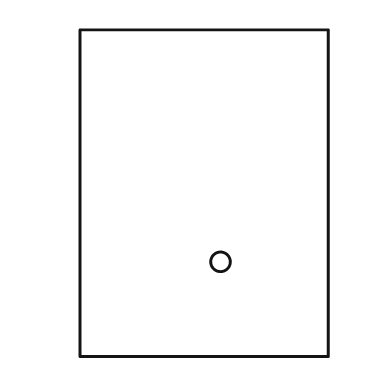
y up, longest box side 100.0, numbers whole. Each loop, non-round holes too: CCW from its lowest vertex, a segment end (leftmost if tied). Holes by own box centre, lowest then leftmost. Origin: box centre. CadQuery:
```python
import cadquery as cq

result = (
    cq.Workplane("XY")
    .moveTo(-38.0, -50.0)
    .lineTo(38.0, -50.0)
    .lineTo(38.0, 50.0)
    .lineTo(-38.0, 50.0)
    .close()
    .moveTo(5.0, -21.0)
    .circle(3.0)
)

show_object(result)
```